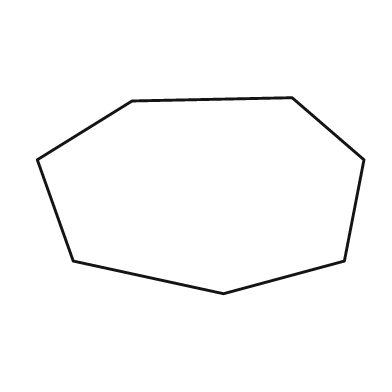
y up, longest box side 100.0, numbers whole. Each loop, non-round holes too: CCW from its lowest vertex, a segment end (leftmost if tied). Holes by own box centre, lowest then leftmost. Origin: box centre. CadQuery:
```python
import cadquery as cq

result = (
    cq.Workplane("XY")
    .moveTo(7.0, -30.0)
    .lineTo(44.0, -20.0)
    .lineTo(50.0, 11.0)
    .lineTo(28.0, 30.0)
    .lineTo(-21.0, 29.0)
    .lineTo(-50.0, 11.0)
    .lineTo(-39.0, -20.0)
    .close()
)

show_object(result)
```